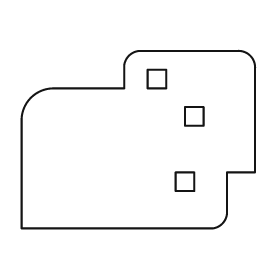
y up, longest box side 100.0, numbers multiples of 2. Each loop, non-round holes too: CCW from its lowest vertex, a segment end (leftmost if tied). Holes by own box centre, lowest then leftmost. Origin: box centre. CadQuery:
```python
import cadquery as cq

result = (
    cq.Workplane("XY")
    .moveTo(-50.0, -38.0)
    .lineTo(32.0, -38.0)
    .threePointArc((36.0, -36.0), (38.0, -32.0))
    .lineTo(38.0, -14.0)
    .lineTo(50.0, -14.0)
    .lineTo(50.0, 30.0)
    .threePointArc((48.0, 36.0), (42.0, 38.0))
    .lineTo(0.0, 38.0)
    .threePointArc((-4.0, 36.0), (-6.0, 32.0))
    .lineTo(-6.0, 22.0)
    .lineTo(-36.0, 22.0)
    .threePointArc((-46.0, 18.0), (-50.0, 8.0))
    .close()
    .moveTo(16.0, -22.0)
    .lineTo(24.0, -22.0)
    .lineTo(24.0, -14.0)
    .lineTo(16.0, -14.0)
    .close()
    .moveTo(20.0, 6.0)
    .lineTo(28.0, 6.0)
    .lineTo(28.0, 14.0)
    .lineTo(20.0, 14.0)
    .close()
    .moveTo(4.0, 22.0)
    .lineTo(12.0, 22.0)
    .lineTo(12.0, 30.0)
    .lineTo(4.0, 30.0)
    .close()
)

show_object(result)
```